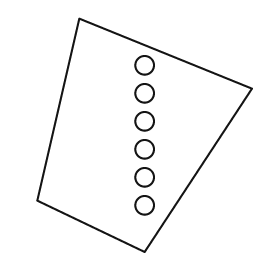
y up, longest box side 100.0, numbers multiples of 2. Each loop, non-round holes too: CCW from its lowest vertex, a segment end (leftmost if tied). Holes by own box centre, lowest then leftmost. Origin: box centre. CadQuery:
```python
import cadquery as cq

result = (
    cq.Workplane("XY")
    .moveTo(0.0, -50.0)
    .lineTo(46.0, 20.0)
    .lineTo(-28.0, 50.0)
    .lineTo(-46.0, -28.0)
    .close()
    .moveTo(0.0, -30.0)
    .circle(4.0)
    .moveTo(0.0, -18.0)
    .circle(4.0)
    .moveTo(0.0, -6.0)
    .circle(4.0)
    .moveTo(0.0, 6.0)
    .circle(4.0)
    .moveTo(0.0, 18.0)
    .circle(4.0)
    .moveTo(0.0, 30.0)
    .circle(4.0)
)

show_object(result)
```